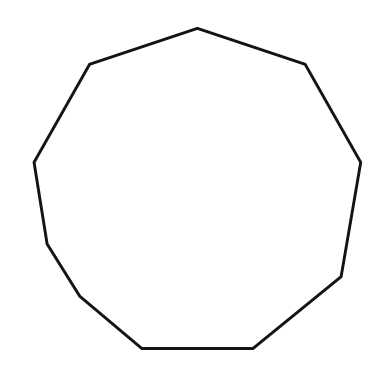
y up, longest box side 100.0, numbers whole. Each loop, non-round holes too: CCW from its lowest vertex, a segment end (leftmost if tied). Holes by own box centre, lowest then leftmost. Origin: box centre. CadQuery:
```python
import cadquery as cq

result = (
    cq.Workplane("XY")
    .moveTo(-17.0, -49.0)
    .lineTo(17.0, -49.0)
    .lineTo(44.0, -27.0)
    .lineTo(50.0, 8.0)
    .lineTo(33.0, 38.0)
    .lineTo(0.0, 49.0)
    .lineTo(-33.0, 38.0)
    .lineTo(-50.0, 8.0)
    .lineTo(-46.0, -17.0)
    .lineTo(-36.0, -33.0)
    .close()
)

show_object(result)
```